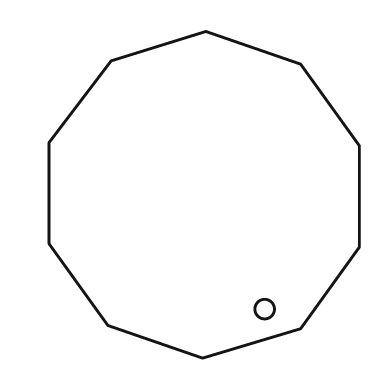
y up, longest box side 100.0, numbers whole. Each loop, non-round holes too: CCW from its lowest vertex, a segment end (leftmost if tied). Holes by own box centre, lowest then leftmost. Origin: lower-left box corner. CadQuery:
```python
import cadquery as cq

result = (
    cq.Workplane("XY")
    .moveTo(47.0, 0.0)
    .lineTo(77.0, 9.0)
    .lineTo(95.0, 34.0)
    .lineTo(95.0, 65.0)
    .lineTo(77.0, 90.0)
    .lineTo(48.0, 100.0)
    .lineTo(19.0, 91.0)
    .lineTo(0.0, 66.0)
    .lineTo(0.0, 35.0)
    .lineTo(18.0, 10.0)
    .close()
    .moveTo(66.0, 15.0)
    .circle(3.0)
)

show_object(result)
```